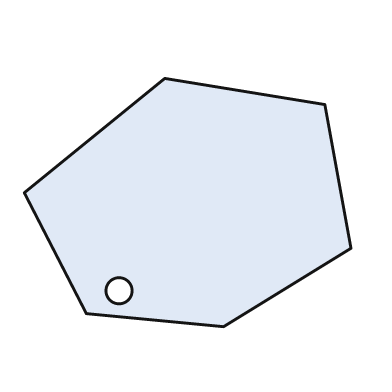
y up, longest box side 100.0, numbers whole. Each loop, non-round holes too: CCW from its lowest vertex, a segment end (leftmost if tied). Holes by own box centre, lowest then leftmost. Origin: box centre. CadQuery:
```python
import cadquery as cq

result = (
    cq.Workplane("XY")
    .moveTo(11.0, -38.0)
    .lineTo(50.0, -14.0)
    .lineTo(42.0, 30.0)
    .lineTo(-7.0, 38.0)
    .lineTo(-50.0, 3.0)
    .lineTo(-31.0, -34.0)
    .close()
    .moveTo(-21.0, -27.0)
    .circle(4.0)
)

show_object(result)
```